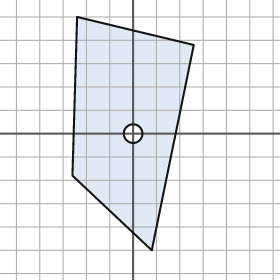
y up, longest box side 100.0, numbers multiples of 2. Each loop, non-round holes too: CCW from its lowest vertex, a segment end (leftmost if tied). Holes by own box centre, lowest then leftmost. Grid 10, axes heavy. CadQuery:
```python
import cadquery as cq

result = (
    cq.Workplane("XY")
    .moveTo(8.0, -50.0)
    .lineTo(26.0, 38.0)
    .lineTo(-24.0, 50.0)
    .lineTo(-26.0, -18.0)
    .close()
    .moveTo(0.0, 0.0)
    .circle(4.0)
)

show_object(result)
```